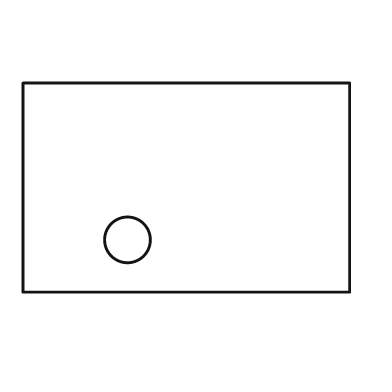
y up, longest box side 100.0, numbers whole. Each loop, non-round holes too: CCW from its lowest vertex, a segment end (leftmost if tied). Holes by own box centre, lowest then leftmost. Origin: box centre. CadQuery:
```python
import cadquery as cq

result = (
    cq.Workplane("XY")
    .moveTo(-50.0, -32.0)
    .lineTo(50.0, -32.0)
    .lineTo(50.0, 32.0)
    .lineTo(-50.0, 32.0)
    .close()
    .moveTo(-18.0, -16.0)
    .circle(7.0)
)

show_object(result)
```